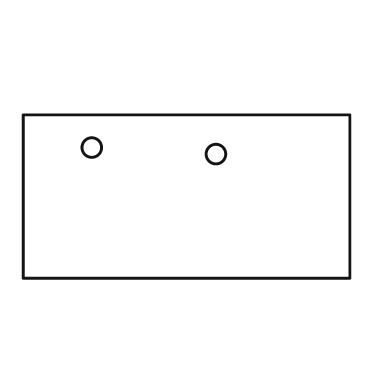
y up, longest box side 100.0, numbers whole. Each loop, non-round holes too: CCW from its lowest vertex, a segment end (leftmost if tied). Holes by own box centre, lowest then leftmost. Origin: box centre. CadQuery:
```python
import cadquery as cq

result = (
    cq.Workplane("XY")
    .moveTo(-50.0, -25.0)
    .lineTo(50.0, -25.0)
    .lineTo(50.0, 25.0)
    .lineTo(-50.0, 25.0)
    .close()
    .moveTo(9.0, 13.0)
    .circle(3.0)
    .moveTo(-29.0, 15.0)
    .circle(3.0)
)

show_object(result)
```